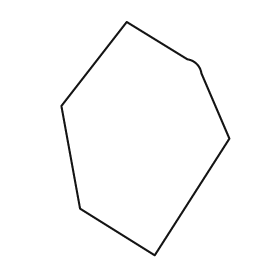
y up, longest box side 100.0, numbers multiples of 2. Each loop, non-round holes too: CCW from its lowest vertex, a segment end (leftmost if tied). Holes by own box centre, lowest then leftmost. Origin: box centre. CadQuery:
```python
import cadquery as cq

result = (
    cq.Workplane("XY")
    .moveTo(4.0, -50.0)
    .lineTo(36.0, 0.0)
    .lineTo(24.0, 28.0)
    .threePointArc((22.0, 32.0), (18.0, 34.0))
    .lineTo(-8.0, 50.0)
    .lineTo(-36.0, 14.0)
    .lineTo(-28.0, -30.0)
    .close()
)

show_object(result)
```